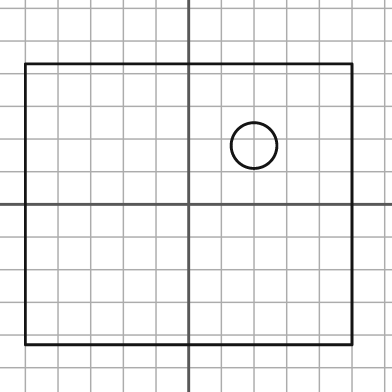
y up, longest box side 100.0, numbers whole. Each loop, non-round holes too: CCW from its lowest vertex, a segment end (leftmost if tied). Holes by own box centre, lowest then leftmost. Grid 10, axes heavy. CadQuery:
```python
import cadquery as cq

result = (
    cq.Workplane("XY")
    .moveTo(-50.0, -43.0)
    .lineTo(50.0, -43.0)
    .lineTo(50.0, 43.0)
    .lineTo(-50.0, 43.0)
    .close()
    .moveTo(20.0, 18.0)
    .circle(7.0)
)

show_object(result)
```